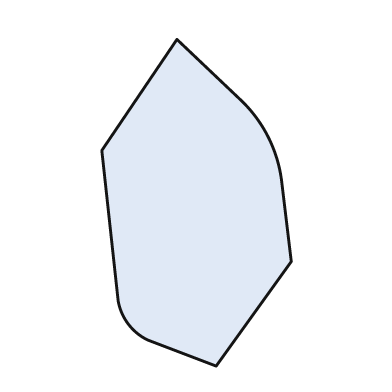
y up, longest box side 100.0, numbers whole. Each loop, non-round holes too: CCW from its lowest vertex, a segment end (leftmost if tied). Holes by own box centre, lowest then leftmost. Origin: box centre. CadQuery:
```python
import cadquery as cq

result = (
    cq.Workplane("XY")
    .moveTo(6.0, -50.0)
    .lineTo(29.0, -18.0)
    .lineTo(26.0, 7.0)
    .threePointArc((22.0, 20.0), (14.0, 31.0))
    .lineTo(-6.0, 50.0)
    .lineTo(-29.0, 16.0)
    .lineTo(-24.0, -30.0)
    .threePointArc((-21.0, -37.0), (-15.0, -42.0))
    .close()
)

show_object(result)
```